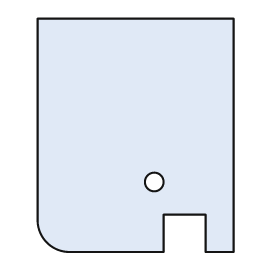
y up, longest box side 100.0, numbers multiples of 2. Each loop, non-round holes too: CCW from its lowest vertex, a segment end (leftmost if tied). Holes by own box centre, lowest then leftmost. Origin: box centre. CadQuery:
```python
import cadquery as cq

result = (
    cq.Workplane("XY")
    .moveTo(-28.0, -50.0)
    .lineTo(12.0, -50.0)
    .lineTo(12.0, -34.0)
    .lineTo(30.0, -34.0)
    .lineTo(30.0, -50.0)
    .lineTo(42.0, -50.0)
    .lineTo(42.0, 50.0)
    .lineTo(-42.0, 50.0)
    .lineTo(-42.0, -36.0)
    .threePointArc((-38.0, -46.0), (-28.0, -50.0))
    .close()
    .moveTo(8.0, -20.0)
    .circle(4.0)
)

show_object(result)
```